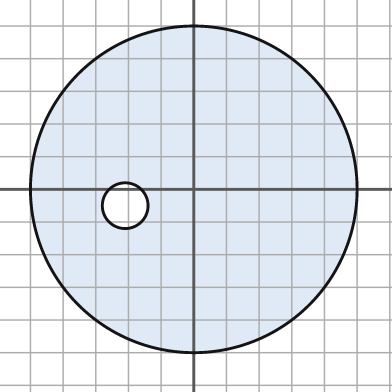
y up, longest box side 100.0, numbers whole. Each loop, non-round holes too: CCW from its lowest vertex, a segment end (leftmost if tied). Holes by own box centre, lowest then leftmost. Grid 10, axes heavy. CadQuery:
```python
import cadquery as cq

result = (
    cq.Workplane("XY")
    .moveTo(0.0, 0.0)
    .circle(50.0)
    .moveTo(-21.0, -5.0)
    .circle(7.0)
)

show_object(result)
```